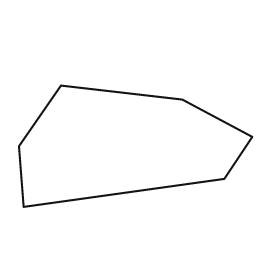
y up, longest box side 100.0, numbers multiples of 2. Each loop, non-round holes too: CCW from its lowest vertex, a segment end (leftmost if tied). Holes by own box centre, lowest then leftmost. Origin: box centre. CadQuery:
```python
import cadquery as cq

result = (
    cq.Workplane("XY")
    .moveTo(-48.0, -26.0)
    .lineTo(38.0, -14.0)
    .lineTo(50.0, 4.0)
    .lineTo(20.0, 20.0)
    .lineTo(-32.0, 26.0)
    .lineTo(-50.0, 0.0)
    .close()
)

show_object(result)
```